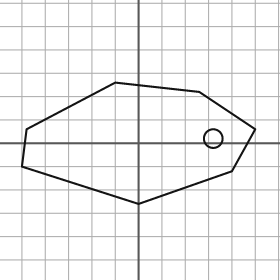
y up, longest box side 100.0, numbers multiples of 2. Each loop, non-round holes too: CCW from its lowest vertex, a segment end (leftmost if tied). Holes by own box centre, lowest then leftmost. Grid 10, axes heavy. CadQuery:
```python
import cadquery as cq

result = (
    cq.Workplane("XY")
    .moveTo(0.0, -26.0)
    .lineTo(40.0, -12.0)
    .lineTo(50.0, 6.0)
    .lineTo(26.0, 22.0)
    .lineTo(-10.0, 26.0)
    .lineTo(-48.0, 6.0)
    .lineTo(-50.0, -10.0)
    .close()
    .moveTo(32.0, 2.0)
    .circle(4.0)
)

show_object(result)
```